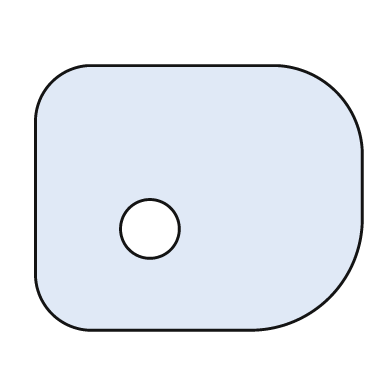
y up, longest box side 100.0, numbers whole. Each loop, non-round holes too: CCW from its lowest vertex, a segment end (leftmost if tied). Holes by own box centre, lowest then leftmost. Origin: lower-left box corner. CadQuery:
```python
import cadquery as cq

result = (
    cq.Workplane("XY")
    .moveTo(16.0, 0.0)
    .lineTo(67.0, 0.0)
    .threePointArc((90.0, 10.0), (100.0, 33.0))
    .lineTo(100.0, 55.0)
    .threePointArc((92.0, 73.0), (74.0, 81.0))
    .lineTo(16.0, 81.0)
    .threePointArc((5.0, 76.0), (0.0, 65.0))
    .lineTo(0.0, 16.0)
    .threePointArc((5.0, 5.0), (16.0, 0.0))
    .close()
    .moveTo(35.0, 31.0)
    .circle(9.0)
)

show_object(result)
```